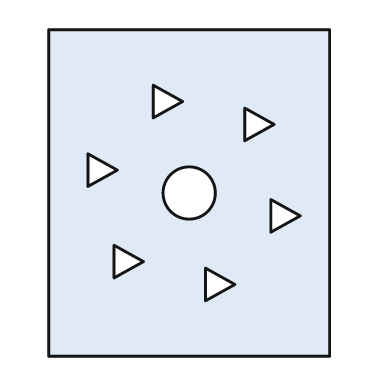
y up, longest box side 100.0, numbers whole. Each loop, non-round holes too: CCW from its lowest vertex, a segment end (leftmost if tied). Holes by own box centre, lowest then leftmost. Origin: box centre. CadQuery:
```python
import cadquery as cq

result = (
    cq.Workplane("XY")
    .moveTo(-43.0, -50.0)
    .lineTo(43.0, -50.0)
    .lineTo(43.0, 50.0)
    .lineTo(-43.0, 50.0)
    .close()
    .moveTo(5.0, -33.0)
    .lineTo(14.0, -28.0)
    .lineTo(5.0, -23.0)
    .close()
    .moveTo(-23.0, -26.0)
    .lineTo(-14.0, -21.0)
    .lineTo(-23.0, -16.0)
    .close()
    .moveTo(25.0, -12.0)
    .lineTo(34.0, -7.0)
    .lineTo(25.0, -2.0)
    .close()
    .moveTo(0.0, 0.0)
    .circle(8.0)
    .moveTo(-31.0, 2.0)
    .lineTo(-22.0, 7.0)
    .lineTo(-31.0, 12.0)
    .close()
    .moveTo(17.0, 16.0)
    .lineTo(26.0, 21.0)
    .lineTo(17.0, 26.0)
    .close()
    .moveTo(-11.0, 23.0)
    .lineTo(-2.0, 28.0)
    .lineTo(-11.0, 33.0)
    .close()
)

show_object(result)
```